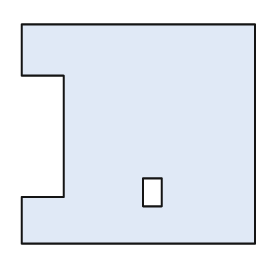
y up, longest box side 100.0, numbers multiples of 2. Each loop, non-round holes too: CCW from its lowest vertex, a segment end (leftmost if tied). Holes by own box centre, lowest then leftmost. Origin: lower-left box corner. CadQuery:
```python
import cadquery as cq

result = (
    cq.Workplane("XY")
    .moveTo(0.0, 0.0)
    .lineTo(100.0, 0.0)
    .lineTo(100.0, 94.0)
    .lineTo(0.0, 94.0)
    .lineTo(0.0, 72.0)
    .lineTo(18.0, 72.0)
    .lineTo(18.0, 20.0)
    .lineTo(0.0, 20.0)
    .close()
    .moveTo(52.0, 16.0)
    .lineTo(60.0, 16.0)
    .lineTo(60.0, 28.0)
    .lineTo(52.0, 28.0)
    .close()
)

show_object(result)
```